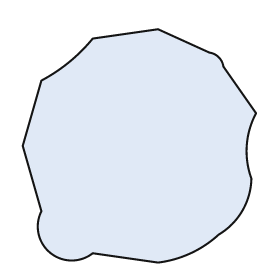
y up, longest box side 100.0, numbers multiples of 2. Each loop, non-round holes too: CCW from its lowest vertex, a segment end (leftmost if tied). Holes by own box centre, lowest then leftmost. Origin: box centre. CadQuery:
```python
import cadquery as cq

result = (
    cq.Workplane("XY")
    .moveTo(8.0, -50.0)
    .threePointArc((22.0, -46.0), (34.0, -38.0))
    .threePointArc((44.0, -28.0), (48.0, -14.0))
    .threePointArc((46.0, 0.0), (50.0, 14.0))
    .lineTo(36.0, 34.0)
    .threePointArc((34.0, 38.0), (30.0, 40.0))
    .lineTo(8.0, 50.0)
    .lineTo(-20.0, 46.0)
    .threePointArc((-30.0, 36.0), (-42.0, 28.0))
    .lineTo(-50.0, 0.0)
    .lineTo(-42.0, -28.0)
    .threePointArc((-38.0, -46.0), (-20.0, -46.0))
    .close()
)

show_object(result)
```